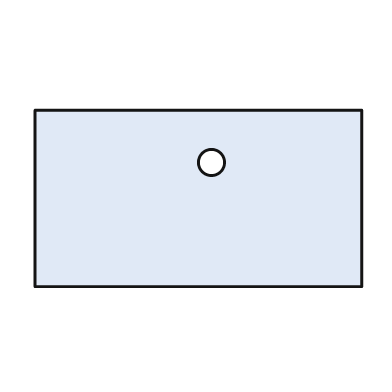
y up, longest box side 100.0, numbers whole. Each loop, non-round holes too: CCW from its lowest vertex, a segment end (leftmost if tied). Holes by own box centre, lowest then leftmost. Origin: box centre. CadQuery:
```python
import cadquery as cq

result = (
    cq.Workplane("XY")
    .moveTo(-50.0, -27.0)
    .lineTo(50.0, -27.0)
    .lineTo(50.0, 27.0)
    .lineTo(-50.0, 27.0)
    .close()
    .moveTo(4.0, 11.0)
    .circle(4.0)
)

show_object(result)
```